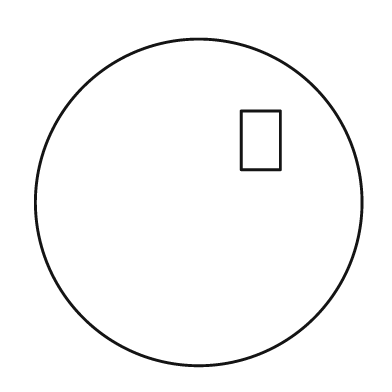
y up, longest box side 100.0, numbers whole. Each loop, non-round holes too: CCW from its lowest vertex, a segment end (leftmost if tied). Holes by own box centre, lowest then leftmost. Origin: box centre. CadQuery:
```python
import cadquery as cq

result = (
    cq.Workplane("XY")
    .moveTo(0.0, 0.0)
    .circle(50.0)
    .moveTo(13.0, 10.0)
    .lineTo(25.0, 10.0)
    .lineTo(25.0, 28.0)
    .lineTo(13.0, 28.0)
    .close()
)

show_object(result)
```